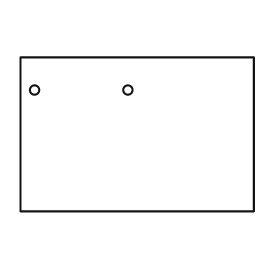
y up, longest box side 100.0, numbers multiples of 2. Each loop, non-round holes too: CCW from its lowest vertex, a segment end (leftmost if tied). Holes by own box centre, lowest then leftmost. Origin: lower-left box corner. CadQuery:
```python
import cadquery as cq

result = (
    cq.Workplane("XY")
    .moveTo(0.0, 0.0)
    .lineTo(100.0, 0.0)
    .lineTo(100.0, 66.0)
    .lineTo(0.0, 66.0)
    .close()
    .moveTo(6.0, 52.0)
    .circle(2.0)
    .moveTo(46.0, 52.0)
    .circle(2.0)
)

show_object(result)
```